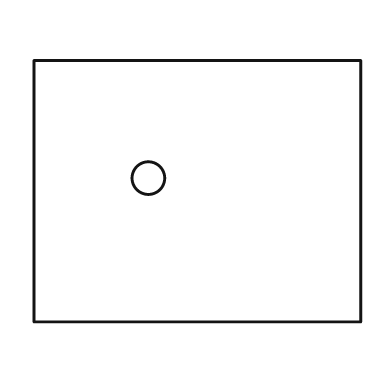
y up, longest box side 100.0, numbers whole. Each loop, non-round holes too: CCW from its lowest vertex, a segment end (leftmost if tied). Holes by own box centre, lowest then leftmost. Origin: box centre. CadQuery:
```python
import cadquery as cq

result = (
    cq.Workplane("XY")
    .moveTo(-50.0, -40.0)
    .lineTo(50.0, -40.0)
    .lineTo(50.0, 40.0)
    .lineTo(-50.0, 40.0)
    .close()
    .moveTo(-15.0, 4.0)
    .circle(5.0)
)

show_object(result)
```